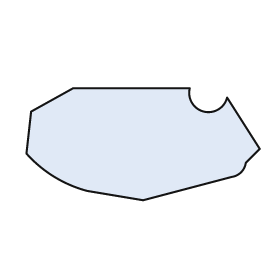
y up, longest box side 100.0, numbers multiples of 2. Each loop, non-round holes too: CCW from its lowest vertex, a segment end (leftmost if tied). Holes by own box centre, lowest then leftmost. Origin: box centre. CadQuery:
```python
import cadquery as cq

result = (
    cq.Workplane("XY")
    .moveTo(0.0, -24.0)
    .lineTo(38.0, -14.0)
    .threePointArc((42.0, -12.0), (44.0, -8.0))
    .lineTo(50.0, -2.0)
    .lineTo(36.0, 20.0)
    .threePointArc((26.0, 14.0), (20.0, 24.0))
    .lineTo(-30.0, 24.0)
    .lineTo(-48.0, 14.0)
    .lineTo(-50.0, -4.0)
    .threePointArc((-38.0, -14.0), (-24.0, -20.0))
    .close()
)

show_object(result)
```